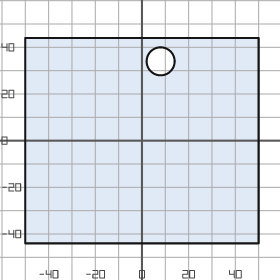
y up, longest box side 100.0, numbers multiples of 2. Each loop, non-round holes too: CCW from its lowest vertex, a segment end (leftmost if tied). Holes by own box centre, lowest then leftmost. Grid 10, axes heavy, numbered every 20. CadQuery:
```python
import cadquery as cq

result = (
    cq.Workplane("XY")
    .moveTo(-50.0, -44.0)
    .lineTo(50.0, -44.0)
    .lineTo(50.0, 44.0)
    .lineTo(-50.0, 44.0)
    .close()
    .moveTo(8.0, 34.0)
    .circle(6.0)
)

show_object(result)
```